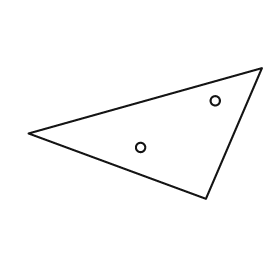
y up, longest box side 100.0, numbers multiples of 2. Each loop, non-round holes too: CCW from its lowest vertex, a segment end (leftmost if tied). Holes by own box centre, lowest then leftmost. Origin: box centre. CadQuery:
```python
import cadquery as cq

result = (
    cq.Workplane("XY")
    .moveTo(26.0, -28.0)
    .lineTo(50.0, 28.0)
    .lineTo(-50.0, 0.0)
    .close()
    .moveTo(-2.0, -6.0)
    .circle(2.0)
    .moveTo(30.0, 14.0)
    .circle(2.0)
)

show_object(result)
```